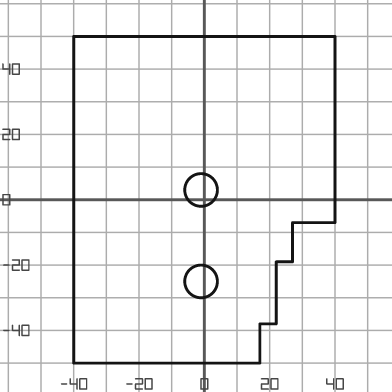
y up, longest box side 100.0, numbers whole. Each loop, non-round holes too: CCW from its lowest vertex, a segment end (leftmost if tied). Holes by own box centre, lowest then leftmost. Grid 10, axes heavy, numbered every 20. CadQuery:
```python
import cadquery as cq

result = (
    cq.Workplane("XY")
    .moveTo(-40.0, -50.0)
    .lineTo(17.0, -50.0)
    .lineTo(17.0, -38.0)
    .lineTo(22.0, -38.0)
    .lineTo(22.0, -19.0)
    .lineTo(27.0, -19.0)
    .lineTo(27.0, -7.0)
    .lineTo(40.0, -7.0)
    .lineTo(40.0, 50.0)
    .lineTo(-40.0, 50.0)
    .close()
    .moveTo(-1.0, -25.0)
    .circle(5.0)
    .moveTo(-1.0, 3.0)
    .circle(5.0)
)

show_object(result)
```